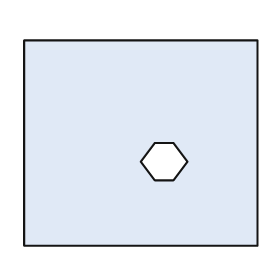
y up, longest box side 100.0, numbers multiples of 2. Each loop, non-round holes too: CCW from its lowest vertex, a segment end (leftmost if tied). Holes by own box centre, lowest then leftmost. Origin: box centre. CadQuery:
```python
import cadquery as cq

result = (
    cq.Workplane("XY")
    .moveTo(-50.0, -44.0)
    .lineTo(50.0, -44.0)
    .lineTo(50.0, 44.0)
    .lineTo(-50.0, 44.0)
    .close()
    .moveTo(6.0, -16.0)
    .lineTo(14.0, -16.0)
    .lineTo(20.0, -8.0)
    .lineTo(14.0, 0.0)
    .lineTo(6.0, 0.0)
    .lineTo(0.0, -8.0)
    .close()
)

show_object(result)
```